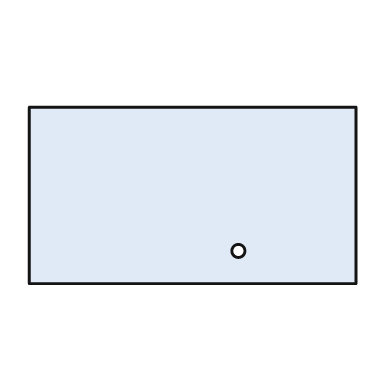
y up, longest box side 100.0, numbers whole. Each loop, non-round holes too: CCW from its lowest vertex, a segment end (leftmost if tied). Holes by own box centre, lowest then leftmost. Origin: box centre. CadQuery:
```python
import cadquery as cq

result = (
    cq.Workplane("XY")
    .moveTo(-50.0, -27.0)
    .lineTo(50.0, -27.0)
    .lineTo(50.0, 27.0)
    .lineTo(-50.0, 27.0)
    .close()
    .moveTo(14.0, -17.0)
    .circle(2.0)
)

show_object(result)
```